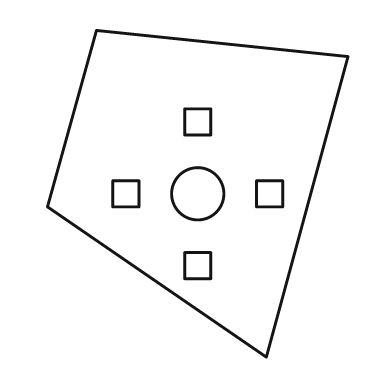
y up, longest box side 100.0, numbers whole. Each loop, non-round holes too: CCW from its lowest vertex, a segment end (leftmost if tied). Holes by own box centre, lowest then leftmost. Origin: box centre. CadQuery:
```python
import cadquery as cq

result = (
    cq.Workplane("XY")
    .moveTo(21.0, -50.0)
    .lineTo(46.0, 42.0)
    .lineTo(-31.0, 50.0)
    .lineTo(-46.0, -4.0)
    .close()
    .moveTo(-4.0, -26.0)
    .lineTo(4.0, -26.0)
    .lineTo(4.0, -18.0)
    .lineTo(-4.0, -18.0)
    .close()
    .moveTo(-26.0, -4.0)
    .lineTo(-18.0, -4.0)
    .lineTo(-18.0, 4.0)
    .lineTo(-26.0, 4.0)
    .close()
    .moveTo(0.0, 0.0)
    .circle(8.0)
    .moveTo(18.0, -4.0)
    .lineTo(26.0, -4.0)
    .lineTo(26.0, 4.0)
    .lineTo(18.0, 4.0)
    .close()
    .moveTo(-4.0, 18.0)
    .lineTo(4.0, 18.0)
    .lineTo(4.0, 26.0)
    .lineTo(-4.0, 26.0)
    .close()
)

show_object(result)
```